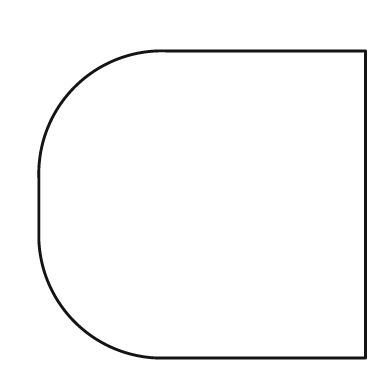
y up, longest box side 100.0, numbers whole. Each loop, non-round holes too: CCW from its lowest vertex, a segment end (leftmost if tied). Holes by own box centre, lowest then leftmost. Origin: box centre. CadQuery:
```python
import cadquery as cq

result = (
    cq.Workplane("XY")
    .moveTo(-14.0, -47.0)
    .lineTo(50.0, -47.0)
    .lineTo(50.0, 47.0)
    .lineTo(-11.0, 47.0)
    .threePointArc((-39.0, 36.0), (-50.0, 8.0))
    .lineTo(-50.0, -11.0)
    .threePointArc((-39.0, -36.0), (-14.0, -47.0))
    .close()
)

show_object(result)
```